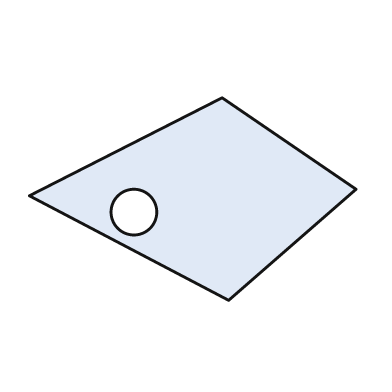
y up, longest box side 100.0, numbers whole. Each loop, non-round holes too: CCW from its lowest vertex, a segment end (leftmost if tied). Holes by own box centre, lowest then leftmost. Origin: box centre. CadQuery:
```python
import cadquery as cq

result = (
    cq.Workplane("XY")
    .moveTo(11.0, -31.0)
    .lineTo(50.0, 3.0)
    .lineTo(9.0, 31.0)
    .lineTo(-50.0, 1.0)
    .close()
    .moveTo(-18.0, -4.0)
    .circle(7.0)
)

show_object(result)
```